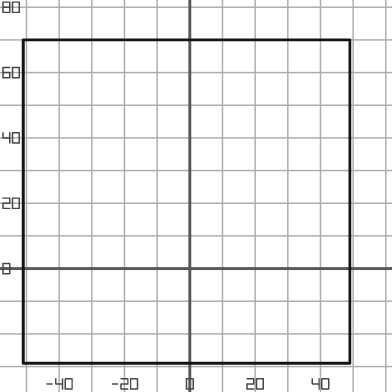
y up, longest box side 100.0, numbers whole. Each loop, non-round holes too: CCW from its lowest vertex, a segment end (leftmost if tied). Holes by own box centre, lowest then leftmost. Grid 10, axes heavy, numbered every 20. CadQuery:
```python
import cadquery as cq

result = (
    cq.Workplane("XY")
    .moveTo(-51.0, -29.0)
    .lineTo(49.0, -29.0)
    .lineTo(49.0, 70.0)
    .lineTo(-51.0, 70.0)
    .close()
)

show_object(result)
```